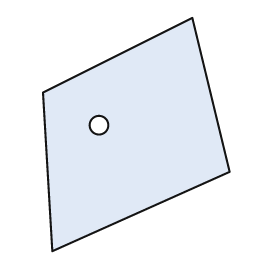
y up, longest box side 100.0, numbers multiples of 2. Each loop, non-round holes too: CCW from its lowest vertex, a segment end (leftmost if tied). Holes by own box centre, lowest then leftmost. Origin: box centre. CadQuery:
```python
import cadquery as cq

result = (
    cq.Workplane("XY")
    .moveTo(-36.0, -50.0)
    .lineTo(40.0, -16.0)
    .lineTo(24.0, 50.0)
    .lineTo(-40.0, 18.0)
    .close()
    .moveTo(-16.0, 4.0)
    .circle(4.0)
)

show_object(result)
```